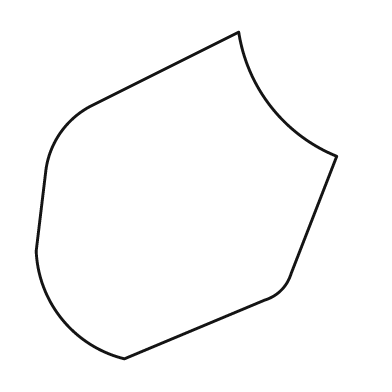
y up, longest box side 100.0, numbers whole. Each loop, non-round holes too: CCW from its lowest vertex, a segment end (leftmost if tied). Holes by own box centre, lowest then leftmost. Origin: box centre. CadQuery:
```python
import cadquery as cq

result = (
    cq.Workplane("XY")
    .moveTo(-19.0, -50.0)
    .lineTo(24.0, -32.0)
    .threePointArc((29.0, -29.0), (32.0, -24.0))
    .lineTo(46.0, 12.0)
    .threePointArc((26.0, 27.0), (16.0, 50.0))
    .lineTo(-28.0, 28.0)
    .threePointArc((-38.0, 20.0), (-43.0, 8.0))
    .lineTo(-46.0, -17.0)
    .threePointArc((-38.0, -38.0), (-19.0, -50.0))
    .close()
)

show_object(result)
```